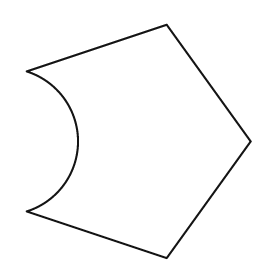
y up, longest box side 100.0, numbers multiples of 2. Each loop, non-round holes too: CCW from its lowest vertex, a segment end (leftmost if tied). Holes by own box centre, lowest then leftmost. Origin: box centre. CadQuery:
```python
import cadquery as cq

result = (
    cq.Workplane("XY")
    .moveTo(12.0, -50.0)
    .lineTo(48.0, 0.0)
    .lineTo(12.0, 50.0)
    .lineTo(-48.0, 30.0)
    .threePointArc((-26.0, 0.0), (-48.0, -30.0))
    .close()
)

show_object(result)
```